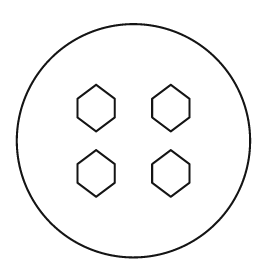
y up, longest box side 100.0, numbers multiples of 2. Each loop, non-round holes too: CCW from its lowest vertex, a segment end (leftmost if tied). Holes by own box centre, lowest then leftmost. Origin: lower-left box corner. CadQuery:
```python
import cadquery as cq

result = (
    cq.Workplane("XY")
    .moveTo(50.0, 50.0)
    .circle(50.0)
    .moveTo(34.0, 26.0)
    .lineTo(42.0, 32.0)
    .lineTo(42.0, 40.0)
    .lineTo(34.0, 46.0)
    .lineTo(26.0, 40.0)
    .lineTo(26.0, 32.0)
    .close()
    .moveTo(66.0, 26.0)
    .lineTo(74.0, 32.0)
    .lineTo(74.0, 40.0)
    .lineTo(66.0, 46.0)
    .lineTo(58.0, 40.0)
    .lineTo(58.0, 32.0)
    .close()
    .moveTo(34.0, 54.0)
    .lineTo(42.0, 60.0)
    .lineTo(42.0, 68.0)
    .lineTo(34.0, 74.0)
    .lineTo(26.0, 68.0)
    .lineTo(26.0, 60.0)
    .close()
    .moveTo(66.0, 54.0)
    .lineTo(74.0, 60.0)
    .lineTo(74.0, 68.0)
    .lineTo(66.0, 74.0)
    .lineTo(58.0, 68.0)
    .lineTo(58.0, 60.0)
    .close()
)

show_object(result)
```